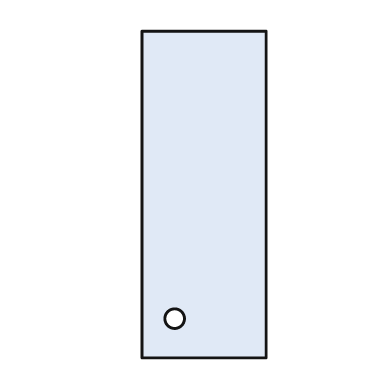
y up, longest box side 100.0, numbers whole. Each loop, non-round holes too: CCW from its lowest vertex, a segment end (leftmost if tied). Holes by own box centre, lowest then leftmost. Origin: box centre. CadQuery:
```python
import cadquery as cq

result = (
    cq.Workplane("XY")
    .moveTo(-19.0, -50.0)
    .lineTo(19.0, -50.0)
    .lineTo(19.0, 50.0)
    .lineTo(-19.0, 50.0)
    .close()
    .moveTo(-9.0, -38.0)
    .circle(3.0)
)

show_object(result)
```